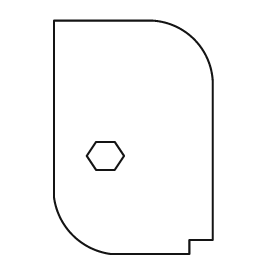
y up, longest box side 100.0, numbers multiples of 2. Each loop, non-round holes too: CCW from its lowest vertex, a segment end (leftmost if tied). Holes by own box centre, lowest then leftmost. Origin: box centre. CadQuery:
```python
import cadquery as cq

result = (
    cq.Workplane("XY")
    .moveTo(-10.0, -50.0)
    .lineTo(24.0, -50.0)
    .lineTo(24.0, -44.0)
    .lineTo(34.0, -44.0)
    .lineTo(34.0, 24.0)
    .threePointArc((26.0, 42.0), (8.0, 50.0))
    .lineTo(-34.0, 50.0)
    .lineTo(-34.0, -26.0)
    .threePointArc((-26.0, -42.0), (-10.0, -50.0))
    .close()
    .moveTo(-16.0, -14.0)
    .lineTo(-8.0, -14.0)
    .lineTo(-4.0, -8.0)
    .lineTo(-8.0, -2.0)
    .lineTo(-16.0, -2.0)
    .lineTo(-20.0, -8.0)
    .close()
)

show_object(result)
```